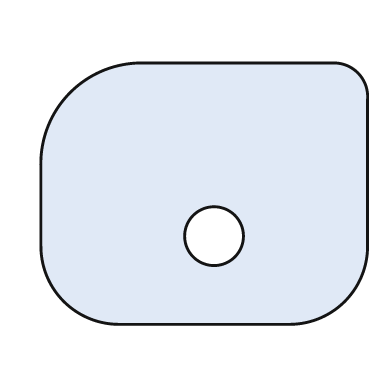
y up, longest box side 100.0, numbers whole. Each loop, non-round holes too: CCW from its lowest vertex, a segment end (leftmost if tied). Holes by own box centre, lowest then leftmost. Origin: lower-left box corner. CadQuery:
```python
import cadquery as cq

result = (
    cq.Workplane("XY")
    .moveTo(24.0, 0.0)
    .lineTo(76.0, 0.0)
    .threePointArc((93.0, 7.0), (100.0, 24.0))
    .lineTo(100.0, 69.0)
    .threePointArc((97.0, 77.0), (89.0, 80.0))
    .lineTo(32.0, 80.0)
    .threePointArc((9.0, 71.0), (0.0, 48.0))
    .lineTo(0.0, 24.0)
    .threePointArc((7.0, 7.0), (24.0, 0.0))
    .close()
    .moveTo(53.0, 27.0)
    .circle(9.0)
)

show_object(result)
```